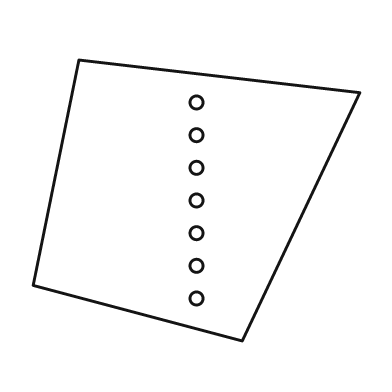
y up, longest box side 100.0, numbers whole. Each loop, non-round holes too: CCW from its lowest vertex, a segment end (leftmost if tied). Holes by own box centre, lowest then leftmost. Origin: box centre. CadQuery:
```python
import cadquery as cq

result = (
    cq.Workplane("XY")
    .moveTo(14.0, -43.0)
    .lineTo(50.0, 33.0)
    .lineTo(-36.0, 43.0)
    .lineTo(-50.0, -26.0)
    .close()
    .moveTo(0.0, -30.0)
    .circle(2.0)
    .moveTo(0.0, -20.0)
    .circle(2.0)
    .moveTo(0.0, -10.0)
    .circle(2.0)
    .moveTo(0.0, 0.0)
    .circle(2.0)
    .moveTo(0.0, 10.0)
    .circle(2.0)
    .moveTo(0.0, 20.0)
    .circle(2.0)
    .moveTo(0.0, 30.0)
    .circle(2.0)
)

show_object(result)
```